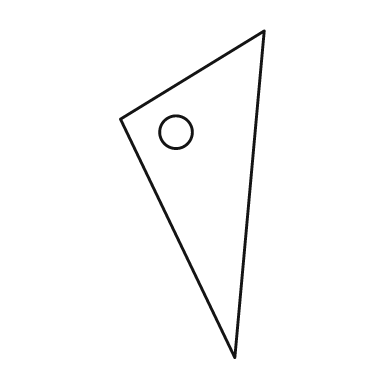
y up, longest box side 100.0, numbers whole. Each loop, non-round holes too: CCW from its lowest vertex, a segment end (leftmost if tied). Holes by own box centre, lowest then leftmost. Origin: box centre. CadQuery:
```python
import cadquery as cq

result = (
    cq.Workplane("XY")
    .moveTo(13.0, -50.0)
    .lineTo(22.0, 50.0)
    .lineTo(-22.0, 23.0)
    .close()
    .moveTo(-5.0, 19.0)
    .circle(5.0)
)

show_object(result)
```